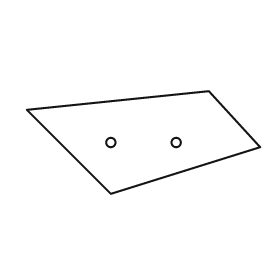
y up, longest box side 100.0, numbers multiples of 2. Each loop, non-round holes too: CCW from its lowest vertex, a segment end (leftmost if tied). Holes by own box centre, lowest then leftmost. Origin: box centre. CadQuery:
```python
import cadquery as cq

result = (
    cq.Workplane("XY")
    .moveTo(-14.0, -22.0)
    .lineTo(50.0, -2.0)
    .lineTo(28.0, 22.0)
    .lineTo(-50.0, 14.0)
    .close()
    .moveTo(-14.0, 0.0)
    .circle(2.0)
    .moveTo(14.0, 0.0)
    .circle(2.0)
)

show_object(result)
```